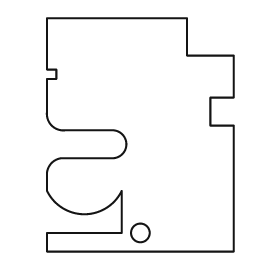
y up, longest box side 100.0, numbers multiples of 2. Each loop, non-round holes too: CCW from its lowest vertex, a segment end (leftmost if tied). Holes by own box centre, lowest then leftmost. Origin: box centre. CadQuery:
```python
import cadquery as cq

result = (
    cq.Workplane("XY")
    .moveTo(-40.0, -50.0)
    .lineTo(40.0, -50.0)
    .lineTo(40.0, 4.0)
    .lineTo(30.0, 4.0)
    .lineTo(30.0, 16.0)
    .lineTo(40.0, 16.0)
    .lineTo(40.0, 34.0)
    .lineTo(20.0, 34.0)
    .lineTo(20.0, 50.0)
    .lineTo(-40.0, 50.0)
    .lineTo(-40.0, 28.0)
    .lineTo(-36.0, 28.0)
    .lineTo(-36.0, 24.0)
    .lineTo(-40.0, 24.0)
    .lineTo(-40.0, 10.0)
    .threePointArc((-38.0, 4.0), (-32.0, 2.0))
    .lineTo(-12.0, 2.0)
    .threePointArc((-6.0, -4.0), (-12.0, -10.0))
    .lineTo(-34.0, -10.0)
    .threePointArc((-38.0, -12.0), (-40.0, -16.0))
    .lineTo(-40.0, -24.0)
    .threePointArc((-24.0, -34.0), (-8.0, -24.0))
    .lineTo(-8.0, -42.0)
    .lineTo(-40.0, -42.0)
    .close()
    .moveTo(0.0, -42.0)
    .circle(4.0)
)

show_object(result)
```